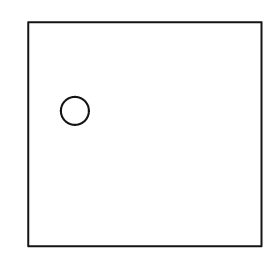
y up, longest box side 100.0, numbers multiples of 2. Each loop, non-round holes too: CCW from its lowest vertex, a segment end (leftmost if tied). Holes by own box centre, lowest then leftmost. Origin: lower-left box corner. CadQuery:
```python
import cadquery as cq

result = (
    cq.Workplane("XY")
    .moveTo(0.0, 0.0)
    .lineTo(100.0, 0.0)
    .lineTo(100.0, 96.0)
    .lineTo(0.0, 96.0)
    .close()
    .moveTo(20.0, 58.0)
    .circle(6.0)
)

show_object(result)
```